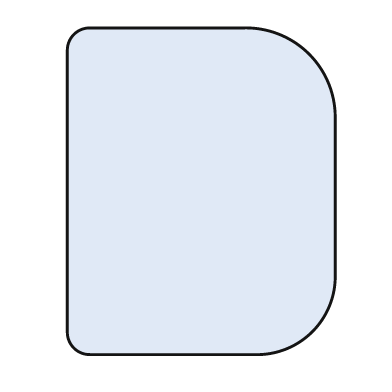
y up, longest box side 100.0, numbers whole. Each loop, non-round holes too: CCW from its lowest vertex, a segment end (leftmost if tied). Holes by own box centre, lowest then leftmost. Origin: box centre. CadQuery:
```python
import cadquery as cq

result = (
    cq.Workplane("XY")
    .moveTo(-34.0, -50.0)
    .lineTo(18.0, -50.0)
    .threePointArc((34.0, -43.0), (41.0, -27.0))
    .lineTo(41.0, 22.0)
    .threePointArc((33.0, 42.0), (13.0, 50.0))
    .lineTo(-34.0, 50.0)
    .threePointArc((-39.0, 48.0), (-41.0, 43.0))
    .lineTo(-41.0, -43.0)
    .threePointArc((-39.0, -48.0), (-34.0, -50.0))
    .close()
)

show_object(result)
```